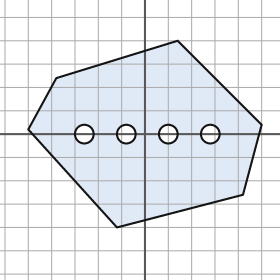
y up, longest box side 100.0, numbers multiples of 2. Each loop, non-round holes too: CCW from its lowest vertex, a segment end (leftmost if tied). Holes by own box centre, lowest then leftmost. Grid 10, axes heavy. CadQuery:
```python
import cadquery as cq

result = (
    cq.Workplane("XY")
    .moveTo(-12.0, -40.0)
    .lineTo(42.0, -26.0)
    .lineTo(50.0, 4.0)
    .lineTo(14.0, 40.0)
    .lineTo(-38.0, 24.0)
    .lineTo(-50.0, 2.0)
    .close()
    .moveTo(-26.0, 0.0)
    .circle(4.0)
    .moveTo(-8.0, 0.0)
    .circle(4.0)
    .moveTo(10.0, 0.0)
    .circle(4.0)
    .moveTo(28.0, 0.0)
    .circle(4.0)
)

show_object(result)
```